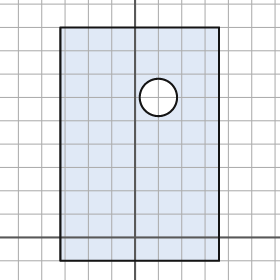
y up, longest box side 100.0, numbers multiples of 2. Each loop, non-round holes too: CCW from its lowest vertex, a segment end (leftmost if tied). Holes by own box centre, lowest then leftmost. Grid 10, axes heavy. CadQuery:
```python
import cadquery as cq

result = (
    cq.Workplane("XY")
    .moveTo(-32.0, -10.0)
    .lineTo(36.0, -10.0)
    .lineTo(36.0, 90.0)
    .lineTo(-32.0, 90.0)
    .close()
    .moveTo(10.0, 60.0)
    .circle(8.0)
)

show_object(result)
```